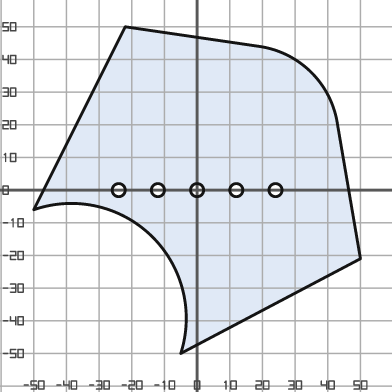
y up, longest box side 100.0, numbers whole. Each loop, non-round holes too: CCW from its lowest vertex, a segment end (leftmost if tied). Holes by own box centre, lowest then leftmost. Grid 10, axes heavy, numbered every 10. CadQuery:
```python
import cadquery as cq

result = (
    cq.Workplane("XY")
    .moveTo(-5.0, -50.0)
    .lineTo(50.0, -21.0)
    .lineTo(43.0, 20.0)
    .threePointArc((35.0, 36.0), (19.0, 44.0))
    .lineTo(-22.0, 50.0)
    .lineTo(-50.0, -6.0)
    .threePointArc((-14.0, -14.0), (-5.0, -50.0))
    .close()
    .moveTo(-24.0, 0.0)
    .circle(2.0)
    .moveTo(-12.0, 0.0)
    .circle(2.0)
    .moveTo(0.0, 0.0)
    .circle(2.0)
    .moveTo(12.0, 0.0)
    .circle(2.0)
    .moveTo(24.0, 0.0)
    .circle(2.0)
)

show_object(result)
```